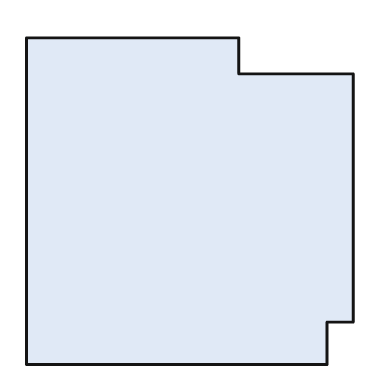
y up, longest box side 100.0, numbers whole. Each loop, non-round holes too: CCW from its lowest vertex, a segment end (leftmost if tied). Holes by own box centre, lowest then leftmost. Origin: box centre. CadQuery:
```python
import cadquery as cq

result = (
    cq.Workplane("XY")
    .moveTo(-50.0, -50.0)
    .lineTo(42.0, -50.0)
    .lineTo(42.0, -37.0)
    .lineTo(50.0, -37.0)
    .lineTo(50.0, 39.0)
    .lineTo(15.0, 39.0)
    .lineTo(15.0, 50.0)
    .lineTo(-50.0, 50.0)
    .close()
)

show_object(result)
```